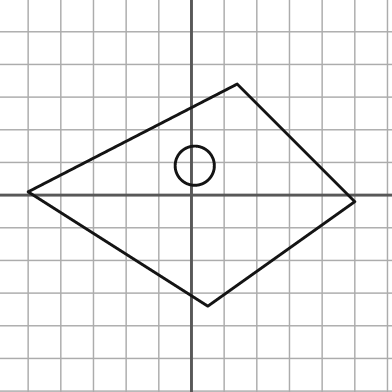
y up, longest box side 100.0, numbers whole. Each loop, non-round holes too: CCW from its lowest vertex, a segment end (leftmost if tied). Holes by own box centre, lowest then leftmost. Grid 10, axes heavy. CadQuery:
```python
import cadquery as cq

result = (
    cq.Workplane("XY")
    .moveTo(5.0, -34.0)
    .lineTo(50.0, -2.0)
    .lineTo(14.0, 34.0)
    .lineTo(-50.0, 1.0)
    .close()
    .moveTo(1.0, 9.0)
    .circle(6.0)
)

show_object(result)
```